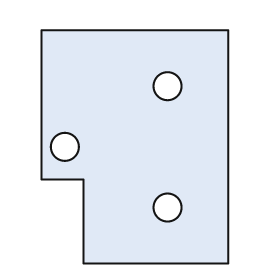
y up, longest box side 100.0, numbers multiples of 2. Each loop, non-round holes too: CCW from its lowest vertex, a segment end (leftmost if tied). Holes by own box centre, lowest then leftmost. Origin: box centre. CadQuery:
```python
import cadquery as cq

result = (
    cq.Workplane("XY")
    .moveTo(-22.0, -50.0)
    .lineTo(40.0, -50.0)
    .lineTo(40.0, 50.0)
    .lineTo(-40.0, 50.0)
    .lineTo(-40.0, -14.0)
    .lineTo(-22.0, -14.0)
    .close()
    .moveTo(14.0, -26.0)
    .circle(6.0)
    .moveTo(-30.0, 0.0)
    .circle(6.0)
    .moveTo(14.0, 26.0)
    .circle(6.0)
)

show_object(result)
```